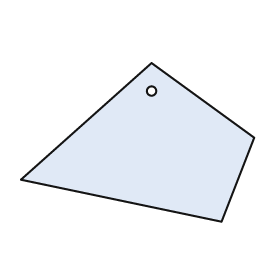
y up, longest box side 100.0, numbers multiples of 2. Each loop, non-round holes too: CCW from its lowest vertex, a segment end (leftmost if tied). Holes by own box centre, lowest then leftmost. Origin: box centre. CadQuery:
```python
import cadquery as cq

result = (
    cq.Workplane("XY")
    .moveTo(36.0, -34.0)
    .lineTo(50.0, 2.0)
    .lineTo(6.0, 34.0)
    .lineTo(-50.0, -16.0)
    .close()
    .moveTo(6.0, 22.0)
    .circle(2.0)
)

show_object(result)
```